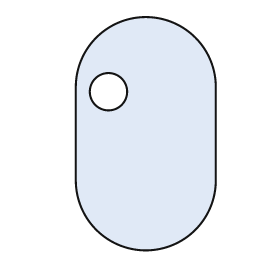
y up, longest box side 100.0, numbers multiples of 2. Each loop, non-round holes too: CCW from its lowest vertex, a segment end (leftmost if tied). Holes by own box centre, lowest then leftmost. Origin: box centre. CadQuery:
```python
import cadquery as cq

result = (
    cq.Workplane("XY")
    .moveTo(-30.0, -20.0)
    .threePointArc((0.0, -50.0), (30.0, -20.0))
    .lineTo(30.0, 20.0)
    .threePointArc((0.0, 50.0), (-30.0, 20.0))
    .close()
    .moveTo(-16.0, 18.0)
    .circle(8.0)
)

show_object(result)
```